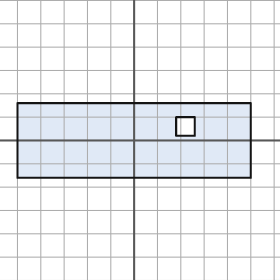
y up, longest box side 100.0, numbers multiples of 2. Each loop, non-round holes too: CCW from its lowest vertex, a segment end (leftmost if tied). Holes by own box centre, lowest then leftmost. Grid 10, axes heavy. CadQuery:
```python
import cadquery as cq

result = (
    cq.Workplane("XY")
    .moveTo(-50.0, -16.0)
    .lineTo(50.0, -16.0)
    .lineTo(50.0, 16.0)
    .lineTo(-50.0, 16.0)
    .close()
    .moveTo(18.0, 2.0)
    .lineTo(26.0, 2.0)
    .lineTo(26.0, 10.0)
    .lineTo(18.0, 10.0)
    .close()
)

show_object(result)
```